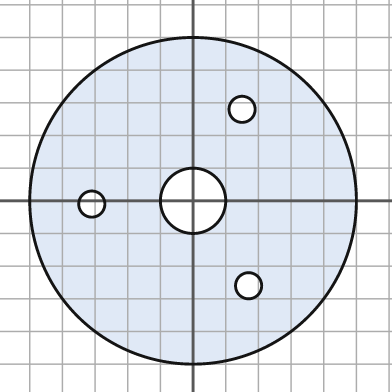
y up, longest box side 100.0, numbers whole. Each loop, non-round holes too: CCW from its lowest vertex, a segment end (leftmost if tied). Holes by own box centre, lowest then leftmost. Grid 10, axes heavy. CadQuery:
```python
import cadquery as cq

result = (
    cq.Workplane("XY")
    .moveTo(0.0, 0.0)
    .circle(50.0)
    .moveTo(17.0, -26.0)
    .circle(4.0)
    .moveTo(-31.0, -1.0)
    .circle(4.0)
    .moveTo(0.0, 0.0)
    .circle(10.0)
    .moveTo(15.0, 28.0)
    .circle(4.0)
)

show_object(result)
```